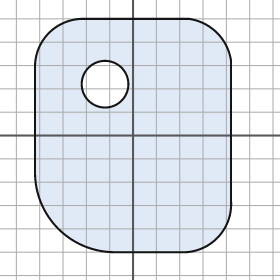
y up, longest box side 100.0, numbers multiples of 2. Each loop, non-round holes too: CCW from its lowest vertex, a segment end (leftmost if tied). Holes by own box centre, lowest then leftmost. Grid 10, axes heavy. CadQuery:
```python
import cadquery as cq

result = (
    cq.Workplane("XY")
    .moveTo(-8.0, -50.0)
    .lineTo(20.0, -50.0)
    .threePointArc((36.0, -44.0), (42.0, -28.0))
    .lineTo(42.0, 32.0)
    .threePointArc((36.0, 44.0), (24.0, 50.0))
    .lineTo(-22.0, 50.0)
    .threePointArc((-36.0, 44.0), (-42.0, 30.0))
    .lineTo(-42.0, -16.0)
    .threePointArc((-32.0, -40.0), (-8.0, -50.0))
    .close()
    .moveTo(-12.0, 22.0)
    .circle(10.0)
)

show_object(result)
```